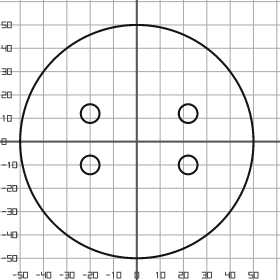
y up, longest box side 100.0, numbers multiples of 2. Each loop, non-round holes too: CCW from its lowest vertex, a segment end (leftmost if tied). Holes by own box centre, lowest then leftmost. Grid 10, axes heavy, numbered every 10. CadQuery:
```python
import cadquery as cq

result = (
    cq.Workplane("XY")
    .moveTo(0.0, 0.0)
    .circle(50.0)
    .moveTo(-20.0, -10.0)
    .circle(4.0)
    .moveTo(22.0, -10.0)
    .circle(4.0)
    .moveTo(-20.0, 12.0)
    .circle(4.0)
    .moveTo(22.0, 12.0)
    .circle(4.0)
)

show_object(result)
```